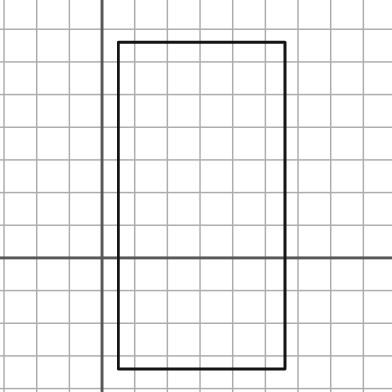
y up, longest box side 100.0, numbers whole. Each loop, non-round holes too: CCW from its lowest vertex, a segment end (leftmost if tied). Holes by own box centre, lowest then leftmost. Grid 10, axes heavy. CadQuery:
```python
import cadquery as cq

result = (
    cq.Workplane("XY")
    .moveTo(5.0, -34.0)
    .lineTo(56.0, -34.0)
    .lineTo(56.0, 66.0)
    .lineTo(5.0, 66.0)
    .close()
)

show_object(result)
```